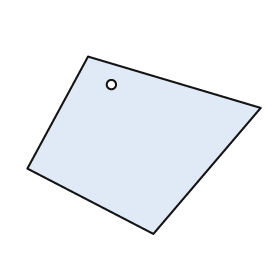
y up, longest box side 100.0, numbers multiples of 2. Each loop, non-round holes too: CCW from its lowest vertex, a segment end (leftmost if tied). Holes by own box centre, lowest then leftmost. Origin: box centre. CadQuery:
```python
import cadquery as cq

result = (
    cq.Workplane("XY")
    .moveTo(4.0, -38.0)
    .lineTo(50.0, 16.0)
    .lineTo(-24.0, 38.0)
    .lineTo(-50.0, -10.0)
    .close()
    .moveTo(-14.0, 26.0)
    .circle(2.0)
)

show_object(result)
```